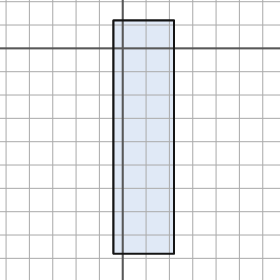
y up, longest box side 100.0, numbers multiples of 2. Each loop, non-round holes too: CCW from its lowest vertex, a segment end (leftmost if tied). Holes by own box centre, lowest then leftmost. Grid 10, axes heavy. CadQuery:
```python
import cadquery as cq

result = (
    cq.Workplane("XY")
    .moveTo(-4.0, -88.0)
    .lineTo(22.0, -88.0)
    .lineTo(22.0, 12.0)
    .lineTo(-4.0, 12.0)
    .close()
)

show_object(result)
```